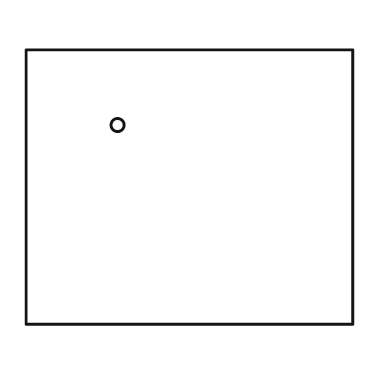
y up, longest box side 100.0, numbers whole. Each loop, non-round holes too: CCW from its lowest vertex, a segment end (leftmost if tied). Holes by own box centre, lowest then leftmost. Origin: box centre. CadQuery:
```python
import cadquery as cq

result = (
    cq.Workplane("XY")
    .moveTo(-50.0, -42.0)
    .lineTo(50.0, -42.0)
    .lineTo(50.0, 42.0)
    .lineTo(-50.0, 42.0)
    .close()
    .moveTo(-22.0, 19.0)
    .circle(2.0)
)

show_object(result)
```